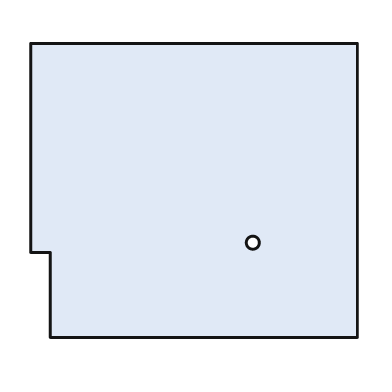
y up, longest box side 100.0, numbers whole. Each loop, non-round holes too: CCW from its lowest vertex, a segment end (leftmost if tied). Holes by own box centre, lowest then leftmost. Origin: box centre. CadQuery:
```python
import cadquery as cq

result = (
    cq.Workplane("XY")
    .moveTo(-44.0, -45.0)
    .lineTo(50.0, -45.0)
    .lineTo(50.0, 45.0)
    .lineTo(-50.0, 45.0)
    .lineTo(-50.0, -19.0)
    .lineTo(-44.0, -19.0)
    .close()
    .moveTo(18.0, -16.0)
    .circle(2.0)
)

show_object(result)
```